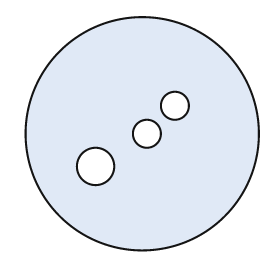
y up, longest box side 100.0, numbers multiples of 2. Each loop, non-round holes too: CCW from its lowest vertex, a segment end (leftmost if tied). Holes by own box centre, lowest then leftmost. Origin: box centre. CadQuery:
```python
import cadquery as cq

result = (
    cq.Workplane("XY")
    .moveTo(0.0, 0.0)
    .circle(50.0)
    .moveTo(-20.0, -14.0)
    .circle(8.0)
    .moveTo(2.0, 0.0)
    .circle(6.0)
    .moveTo(14.0, 12.0)
    .circle(6.0)
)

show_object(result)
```